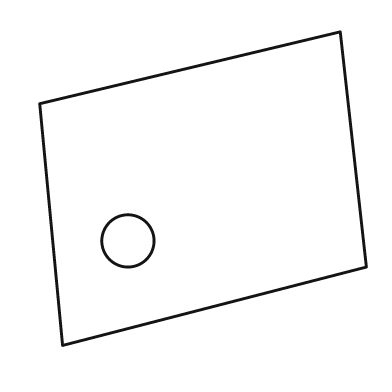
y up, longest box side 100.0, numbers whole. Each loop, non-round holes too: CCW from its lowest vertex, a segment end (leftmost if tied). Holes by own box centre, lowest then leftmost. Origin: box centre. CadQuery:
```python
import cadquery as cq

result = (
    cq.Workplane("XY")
    .moveTo(-43.0, -48.0)
    .lineTo(50.0, -24.0)
    .lineTo(42.0, 48.0)
    .lineTo(-50.0, 26.0)
    .close()
    .moveTo(-23.0, -16.0)
    .circle(8.0)
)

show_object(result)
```